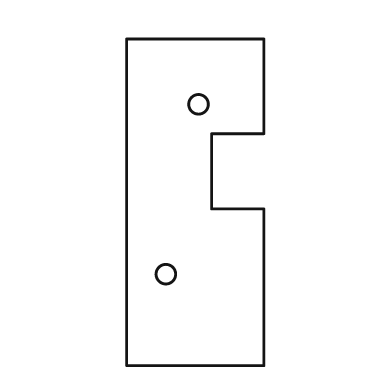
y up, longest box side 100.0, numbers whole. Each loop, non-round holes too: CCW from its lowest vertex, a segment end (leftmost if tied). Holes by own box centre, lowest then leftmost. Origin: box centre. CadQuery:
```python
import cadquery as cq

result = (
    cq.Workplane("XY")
    .moveTo(-21.0, -50.0)
    .lineTo(21.0, -50.0)
    .lineTo(21.0, -2.0)
    .lineTo(5.0, -2.0)
    .lineTo(5.0, 21.0)
    .lineTo(21.0, 21.0)
    .lineTo(21.0, 50.0)
    .lineTo(-21.0, 50.0)
    .close()
    .moveTo(-9.0, -22.0)
    .circle(3.0)
    .moveTo(1.0, 30.0)
    .circle(3.0)
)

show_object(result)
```